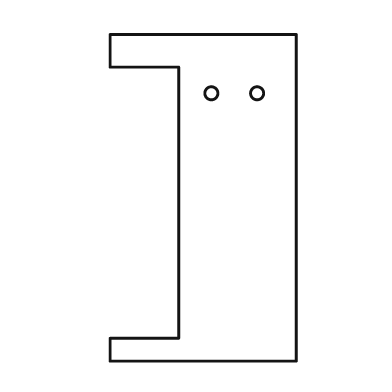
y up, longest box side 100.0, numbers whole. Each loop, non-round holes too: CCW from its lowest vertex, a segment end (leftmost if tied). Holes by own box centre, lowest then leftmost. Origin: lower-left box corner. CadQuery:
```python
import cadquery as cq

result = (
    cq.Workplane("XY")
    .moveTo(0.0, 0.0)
    .lineTo(57.0, 0.0)
    .lineTo(57.0, 100.0)
    .lineTo(0.0, 100.0)
    .lineTo(0.0, 90.0)
    .lineTo(21.0, 90.0)
    .lineTo(21.0, 7.0)
    .lineTo(0.0, 7.0)
    .close()
    .moveTo(31.0, 82.0)
    .circle(2.0)
    .moveTo(45.0, 82.0)
    .circle(2.0)
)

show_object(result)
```